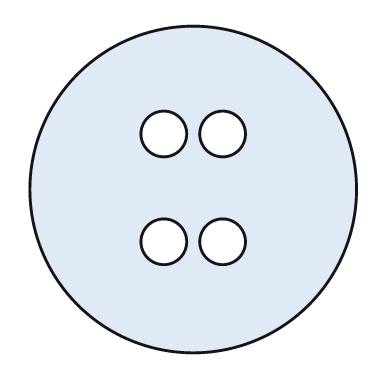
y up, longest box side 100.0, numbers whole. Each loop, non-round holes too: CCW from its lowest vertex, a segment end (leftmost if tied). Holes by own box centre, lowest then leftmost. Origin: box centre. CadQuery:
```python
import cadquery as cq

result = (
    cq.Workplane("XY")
    .moveTo(0.0, 0.0)
    .circle(50.0)
    .moveTo(-9.0, -16.0)
    .circle(7.0)
    .moveTo(9.0, -16.0)
    .circle(7.0)
    .moveTo(-9.0, 17.0)
    .circle(7.0)
    .moveTo(9.0, 17.0)
    .circle(7.0)
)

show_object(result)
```